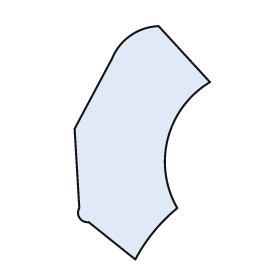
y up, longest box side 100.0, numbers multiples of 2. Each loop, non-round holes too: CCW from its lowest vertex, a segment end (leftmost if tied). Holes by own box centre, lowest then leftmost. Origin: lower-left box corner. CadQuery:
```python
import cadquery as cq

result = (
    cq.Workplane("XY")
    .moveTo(26.0, 0.0)
    .threePointArc((34.0, 12.0), (44.0, 22.0))
    .threePointArc((40.0, 52.0), (58.0, 76.0))
    .lineTo(36.0, 100.0)
    .threePointArc((24.0, 96.0), (16.0, 86.0))
    .lineTo(0.0, 56.0)
    .lineTo(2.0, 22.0)
    .threePointArc((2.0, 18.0), (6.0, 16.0))
    .close()
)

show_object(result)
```